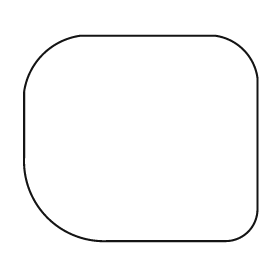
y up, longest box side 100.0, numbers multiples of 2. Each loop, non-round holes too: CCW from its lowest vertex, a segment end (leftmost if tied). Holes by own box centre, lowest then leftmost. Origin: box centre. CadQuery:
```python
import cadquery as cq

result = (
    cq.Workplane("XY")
    .moveTo(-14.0, -44.0)
    .lineTo(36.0, -44.0)
    .threePointArc((46.0, -40.0), (50.0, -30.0))
    .lineTo(50.0, 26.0)
    .threePointArc((44.0, 38.0), (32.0, 44.0))
    .lineTo(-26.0, 44.0)
    .threePointArc((-42.0, 36.0), (-50.0, 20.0))
    .lineTo(-50.0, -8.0)
    .threePointArc((-40.0, -34.0), (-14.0, -44.0))
    .close()
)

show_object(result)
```